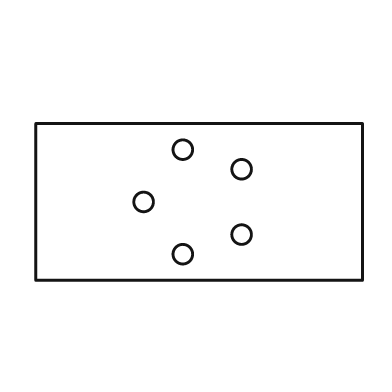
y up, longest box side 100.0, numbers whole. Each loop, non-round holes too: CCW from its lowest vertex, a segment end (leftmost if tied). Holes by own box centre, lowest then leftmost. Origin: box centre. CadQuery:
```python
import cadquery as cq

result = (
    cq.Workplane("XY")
    .moveTo(-50.0, -24.0)
    .lineTo(50.0, -24.0)
    .lineTo(50.0, 24.0)
    .lineTo(-50.0, 24.0)
    .close()
    .moveTo(-5.0, -16.0)
    .circle(3.0)
    .moveTo(13.0, -10.0)
    .circle(3.0)
    .moveTo(-17.0, 0.0)
    .circle(3.0)
    .moveTo(13.0, 10.0)
    .circle(3.0)
    .moveTo(-5.0, 16.0)
    .circle(3.0)
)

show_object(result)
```